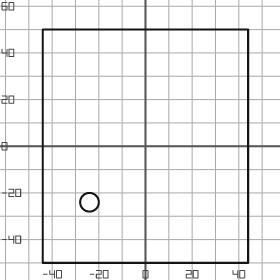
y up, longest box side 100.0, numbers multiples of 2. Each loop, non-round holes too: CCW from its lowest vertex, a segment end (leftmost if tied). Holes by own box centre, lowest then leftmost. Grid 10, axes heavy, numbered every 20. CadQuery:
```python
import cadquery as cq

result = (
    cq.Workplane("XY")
    .moveTo(-44.0, -50.0)
    .lineTo(44.0, -50.0)
    .lineTo(44.0, 50.0)
    .lineTo(-44.0, 50.0)
    .close()
    .moveTo(-24.0, -24.0)
    .circle(4.0)
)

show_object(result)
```